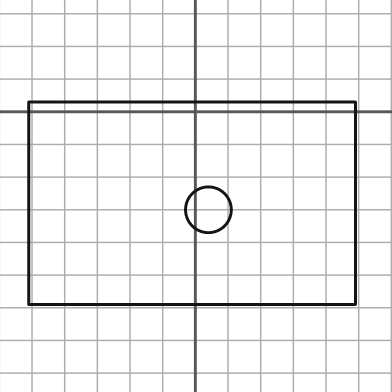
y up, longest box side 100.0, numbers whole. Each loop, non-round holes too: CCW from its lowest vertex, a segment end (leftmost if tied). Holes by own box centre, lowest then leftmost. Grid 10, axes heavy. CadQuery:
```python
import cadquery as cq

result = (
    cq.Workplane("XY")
    .moveTo(-51.0, -59.0)
    .lineTo(49.0, -59.0)
    .lineTo(49.0, 3.0)
    .lineTo(-51.0, 3.0)
    .close()
    .moveTo(4.0, -30.0)
    .circle(7.0)
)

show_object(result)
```